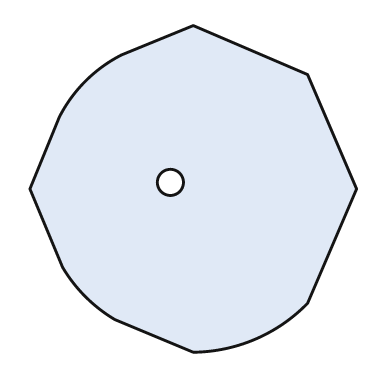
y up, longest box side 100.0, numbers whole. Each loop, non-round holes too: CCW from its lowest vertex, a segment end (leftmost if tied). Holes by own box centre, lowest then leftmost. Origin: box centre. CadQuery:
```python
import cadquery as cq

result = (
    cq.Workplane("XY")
    .moveTo(0.0, -50.0)
    .threePointArc((19.0, -46.0), (35.0, -35.0))
    .lineTo(50.0, 0.0)
    .lineTo(35.0, 35.0)
    .lineTo(0.0, 50.0)
    .lineTo(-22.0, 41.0)
    .threePointArc((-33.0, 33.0), (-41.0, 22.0))
    .lineTo(-50.0, 0.0)
    .lineTo(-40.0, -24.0)
    .threePointArc((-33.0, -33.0), (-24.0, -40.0))
    .close()
    .moveTo(-7.0, 2.0)
    .circle(4.0)
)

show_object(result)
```